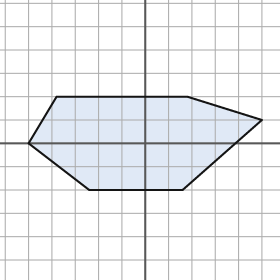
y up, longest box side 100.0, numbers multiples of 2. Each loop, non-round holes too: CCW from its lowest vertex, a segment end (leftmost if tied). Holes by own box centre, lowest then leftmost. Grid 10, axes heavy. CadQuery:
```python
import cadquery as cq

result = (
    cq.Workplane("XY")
    .moveTo(-24.0, -20.0)
    .lineTo(16.0, -20.0)
    .lineTo(50.0, 10.0)
    .lineTo(18.0, 20.0)
    .lineTo(-38.0, 20.0)
    .lineTo(-50.0, 0.0)
    .close()
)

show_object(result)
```